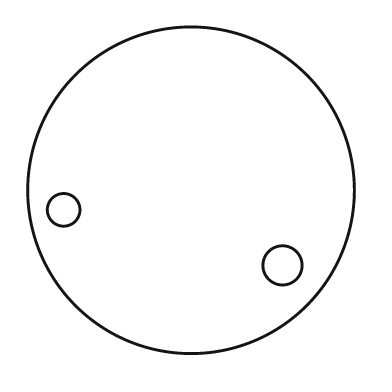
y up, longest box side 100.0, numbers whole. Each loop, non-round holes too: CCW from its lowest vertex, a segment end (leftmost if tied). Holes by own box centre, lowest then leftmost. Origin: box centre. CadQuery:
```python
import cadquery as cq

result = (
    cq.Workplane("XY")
    .moveTo(0.0, 0.0)
    .circle(50.0)
    .moveTo(28.0, -23.0)
    .circle(6.0)
    .moveTo(-39.0, -6.0)
    .circle(5.0)
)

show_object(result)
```